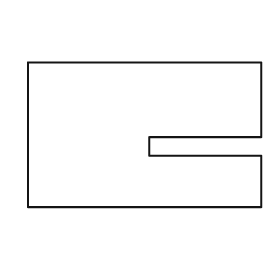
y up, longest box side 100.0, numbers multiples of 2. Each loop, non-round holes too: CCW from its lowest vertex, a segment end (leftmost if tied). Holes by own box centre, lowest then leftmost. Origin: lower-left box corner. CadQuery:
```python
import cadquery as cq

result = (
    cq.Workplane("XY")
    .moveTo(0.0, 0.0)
    .lineTo(100.0, 0.0)
    .lineTo(100.0, 22.0)
    .lineTo(52.0, 22.0)
    .lineTo(52.0, 30.0)
    .lineTo(100.0, 30.0)
    .lineTo(100.0, 62.0)
    .lineTo(0.0, 62.0)
    .close()
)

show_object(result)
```